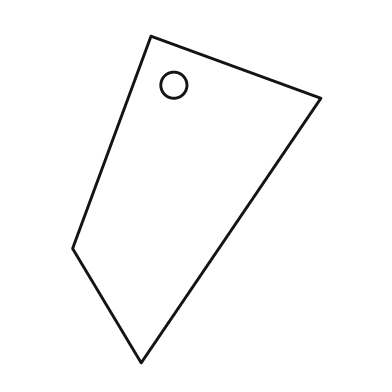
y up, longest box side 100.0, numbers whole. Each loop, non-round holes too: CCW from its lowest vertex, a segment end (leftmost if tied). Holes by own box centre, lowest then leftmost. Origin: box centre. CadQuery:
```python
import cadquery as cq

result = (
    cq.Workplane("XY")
    .moveTo(-17.0, -50.0)
    .lineTo(38.0, 31.0)
    .lineTo(-14.0, 50.0)
    .lineTo(-38.0, -15.0)
    .close()
    .moveTo(-7.0, 35.0)
    .circle(4.0)
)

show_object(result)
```